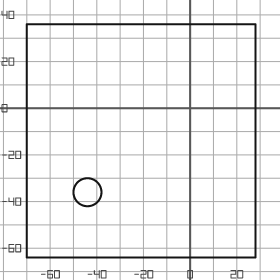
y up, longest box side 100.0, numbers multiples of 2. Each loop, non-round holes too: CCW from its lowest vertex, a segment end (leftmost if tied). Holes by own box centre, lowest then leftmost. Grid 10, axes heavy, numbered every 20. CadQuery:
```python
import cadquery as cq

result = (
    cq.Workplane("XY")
    .moveTo(-70.0, -64.0)
    .lineTo(28.0, -64.0)
    .lineTo(28.0, 36.0)
    .lineTo(-70.0, 36.0)
    .close()
    .moveTo(-44.0, -36.0)
    .circle(6.0)
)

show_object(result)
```